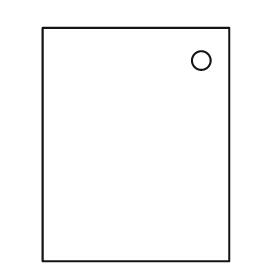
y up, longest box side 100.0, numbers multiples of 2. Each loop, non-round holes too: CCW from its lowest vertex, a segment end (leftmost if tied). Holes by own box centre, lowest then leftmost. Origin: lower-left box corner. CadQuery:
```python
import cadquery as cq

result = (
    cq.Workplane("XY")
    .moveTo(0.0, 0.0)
    .lineTo(80.0, 0.0)
    .lineTo(80.0, 100.0)
    .lineTo(0.0, 100.0)
    .close()
    .moveTo(68.0, 86.0)
    .circle(4.0)
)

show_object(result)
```